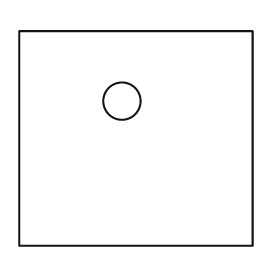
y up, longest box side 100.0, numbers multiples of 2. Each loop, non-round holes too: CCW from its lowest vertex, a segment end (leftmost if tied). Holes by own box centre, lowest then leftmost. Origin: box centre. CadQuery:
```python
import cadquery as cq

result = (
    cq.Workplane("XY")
    .moveTo(-50.0, -46.0)
    .lineTo(50.0, -46.0)
    .lineTo(50.0, 46.0)
    .lineTo(-50.0, 46.0)
    .close()
    .moveTo(-6.0, 16.0)
    .circle(8.0)
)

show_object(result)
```